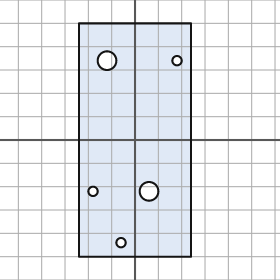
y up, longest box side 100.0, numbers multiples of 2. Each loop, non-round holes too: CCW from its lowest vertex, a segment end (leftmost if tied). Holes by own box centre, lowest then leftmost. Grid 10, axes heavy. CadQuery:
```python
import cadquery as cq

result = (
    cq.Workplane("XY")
    .moveTo(-24.0, -50.0)
    .lineTo(24.0, -50.0)
    .lineTo(24.0, 50.0)
    .lineTo(-24.0, 50.0)
    .close()
    .moveTo(-6.0, -44.0)
    .circle(2.0)
    .moveTo(-18.0, -22.0)
    .circle(2.0)
    .moveTo(6.0, -22.0)
    .circle(4.0)
    .moveTo(-12.0, 34.0)
    .circle(4.0)
    .moveTo(18.0, 34.0)
    .circle(2.0)
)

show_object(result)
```